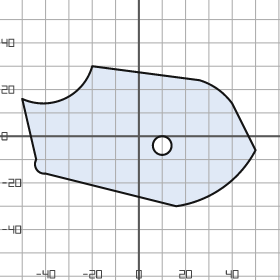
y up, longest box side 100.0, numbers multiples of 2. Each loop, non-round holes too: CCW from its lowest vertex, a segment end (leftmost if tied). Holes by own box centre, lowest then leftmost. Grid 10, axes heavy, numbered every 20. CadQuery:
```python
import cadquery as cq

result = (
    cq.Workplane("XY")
    .moveTo(16.0, -30.0)
    .threePointArc((36.0, -22.0), (50.0, -6.0))
    .lineTo(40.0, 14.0)
    .threePointArc((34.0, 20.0), (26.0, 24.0))
    .lineTo(-20.0, 30.0)
    .threePointArc((-32.0, 16.0), (-50.0, 16.0))
    .lineTo(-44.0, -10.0)
    .threePointArc((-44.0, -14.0), (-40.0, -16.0))
    .close()
    .moveTo(10.0, -4.0)
    .circle(4.0)
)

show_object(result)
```